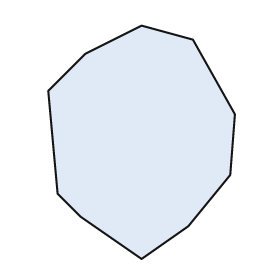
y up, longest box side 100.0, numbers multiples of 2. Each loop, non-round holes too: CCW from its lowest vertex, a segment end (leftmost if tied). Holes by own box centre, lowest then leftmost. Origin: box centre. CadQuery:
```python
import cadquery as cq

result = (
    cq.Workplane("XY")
    .moveTo(0.0, -50.0)
    .lineTo(20.0, -36.0)
    .lineTo(38.0, -14.0)
    .lineTo(40.0, 12.0)
    .lineTo(22.0, 44.0)
    .lineTo(0.0, 50.0)
    .lineTo(-24.0, 38.0)
    .lineTo(-40.0, 22.0)
    .lineTo(-36.0, -22.0)
    .lineTo(-26.0, -32.0)
    .close()
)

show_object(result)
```